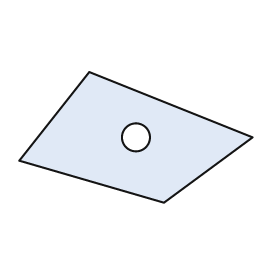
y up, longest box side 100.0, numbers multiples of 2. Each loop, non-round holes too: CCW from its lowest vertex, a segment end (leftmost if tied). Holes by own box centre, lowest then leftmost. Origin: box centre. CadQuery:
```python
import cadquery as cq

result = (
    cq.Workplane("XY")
    .moveTo(12.0, -28.0)
    .lineTo(50.0, 0.0)
    .lineTo(-20.0, 28.0)
    .lineTo(-50.0, -10.0)
    .close()
    .moveTo(0.0, 0.0)
    .circle(6.0)
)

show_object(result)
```